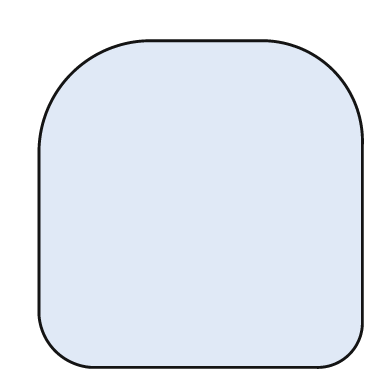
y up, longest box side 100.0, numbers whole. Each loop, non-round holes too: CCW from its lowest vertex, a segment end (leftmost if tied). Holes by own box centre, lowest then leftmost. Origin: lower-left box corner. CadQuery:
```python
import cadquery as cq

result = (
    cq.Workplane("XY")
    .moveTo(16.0, 0.0)
    .lineTo(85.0, 0.0)
    .threePointArc((95.0, 4.0), (99.0, 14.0))
    .lineTo(99.0, 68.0)
    .threePointArc((90.0, 91.0), (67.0, 100.0))
    .lineTo(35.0, 100.0)
    .threePointArc((10.0, 90.0), (0.0, 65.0))
    .lineTo(0.0, 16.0)
    .threePointArc((5.0, 5.0), (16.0, 0.0))
    .close()
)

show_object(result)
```